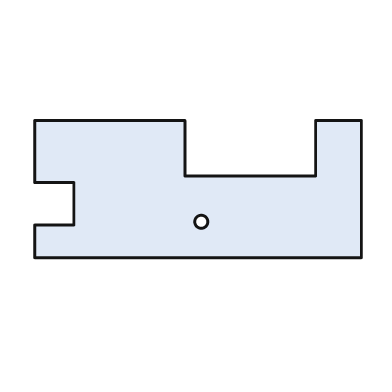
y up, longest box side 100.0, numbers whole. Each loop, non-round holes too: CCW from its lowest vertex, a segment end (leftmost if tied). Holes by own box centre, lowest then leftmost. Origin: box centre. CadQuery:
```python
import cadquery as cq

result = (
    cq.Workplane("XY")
    .moveTo(-50.0, -21.0)
    .lineTo(50.0, -21.0)
    .lineTo(50.0, 21.0)
    .lineTo(36.0, 21.0)
    .lineTo(36.0, 4.0)
    .lineTo(-4.0, 4.0)
    .lineTo(-4.0, 21.0)
    .lineTo(-50.0, 21.0)
    .lineTo(-50.0, 2.0)
    .lineTo(-38.0, 2.0)
    .lineTo(-38.0, -11.0)
    .lineTo(-50.0, -11.0)
    .close()
    .moveTo(1.0, -10.0)
    .circle(2.0)
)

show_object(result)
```